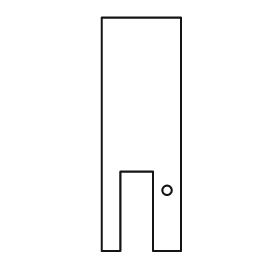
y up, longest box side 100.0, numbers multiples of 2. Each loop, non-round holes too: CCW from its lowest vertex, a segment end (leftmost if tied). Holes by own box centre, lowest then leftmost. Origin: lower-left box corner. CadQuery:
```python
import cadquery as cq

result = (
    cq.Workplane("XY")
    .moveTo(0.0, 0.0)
    .lineTo(8.0, 0.0)
    .lineTo(8.0, 34.0)
    .lineTo(22.0, 34.0)
    .lineTo(22.0, 0.0)
    .lineTo(34.0, 0.0)
    .lineTo(34.0, 100.0)
    .lineTo(0.0, 100.0)
    .close()
    .moveTo(28.0, 26.0)
    .circle(2.0)
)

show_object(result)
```